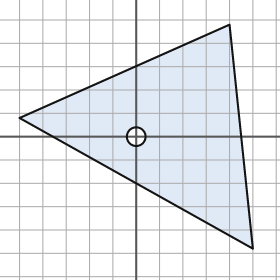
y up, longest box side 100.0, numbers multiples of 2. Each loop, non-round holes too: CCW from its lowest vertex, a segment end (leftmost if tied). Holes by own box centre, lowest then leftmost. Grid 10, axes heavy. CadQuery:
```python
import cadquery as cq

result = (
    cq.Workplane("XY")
    .moveTo(50.0, -48.0)
    .lineTo(40.0, 48.0)
    .lineTo(-50.0, 8.0)
    .close()
    .moveTo(0.0, 0.0)
    .circle(4.0)
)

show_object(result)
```